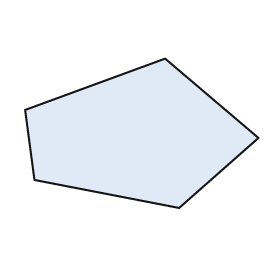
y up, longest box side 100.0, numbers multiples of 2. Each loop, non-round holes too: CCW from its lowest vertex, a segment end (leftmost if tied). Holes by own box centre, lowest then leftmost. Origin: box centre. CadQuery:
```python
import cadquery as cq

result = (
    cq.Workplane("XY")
    .moveTo(16.0, -32.0)
    .lineTo(50.0, -2.0)
    .lineTo(10.0, 32.0)
    .lineTo(-50.0, 10.0)
    .lineTo(-46.0, -20.0)
    .close()
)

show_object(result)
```